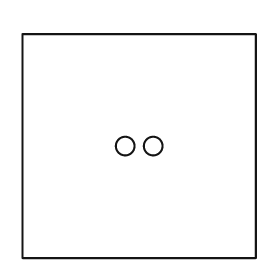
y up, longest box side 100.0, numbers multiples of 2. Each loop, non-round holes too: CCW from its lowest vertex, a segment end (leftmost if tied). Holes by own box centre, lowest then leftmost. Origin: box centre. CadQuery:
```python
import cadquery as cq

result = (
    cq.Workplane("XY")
    .moveTo(-50.0, -48.0)
    .lineTo(50.0, -48.0)
    .lineTo(50.0, 48.0)
    .lineTo(-50.0, 48.0)
    .close()
    .moveTo(-6.0, 0.0)
    .circle(4.0)
    .moveTo(6.0, 0.0)
    .circle(4.0)
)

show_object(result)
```